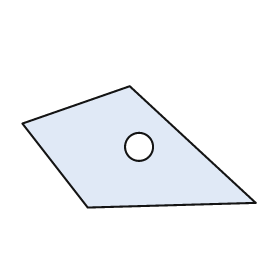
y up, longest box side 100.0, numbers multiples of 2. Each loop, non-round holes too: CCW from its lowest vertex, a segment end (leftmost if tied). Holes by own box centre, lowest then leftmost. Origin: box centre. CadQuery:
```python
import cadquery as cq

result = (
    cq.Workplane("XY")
    .moveTo(-22.0, -26.0)
    .lineTo(50.0, -24.0)
    .lineTo(-4.0, 26.0)
    .lineTo(-50.0, 10.0)
    .close()
    .moveTo(0.0, 0.0)
    .circle(6.0)
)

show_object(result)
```